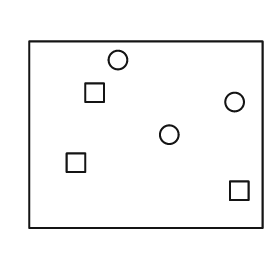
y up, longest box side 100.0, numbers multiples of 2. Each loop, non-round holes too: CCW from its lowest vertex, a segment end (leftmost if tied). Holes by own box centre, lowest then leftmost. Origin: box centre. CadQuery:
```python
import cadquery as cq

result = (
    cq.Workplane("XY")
    .moveTo(-50.0, -40.0)
    .lineTo(50.0, -40.0)
    .lineTo(50.0, 40.0)
    .lineTo(-50.0, 40.0)
    .close()
    .moveTo(36.0, -28.0)
    .lineTo(44.0, -28.0)
    .lineTo(44.0, -20.0)
    .lineTo(36.0, -20.0)
    .close()
    .moveTo(-34.0, -16.0)
    .lineTo(-26.0, -16.0)
    .lineTo(-26.0, -8.0)
    .lineTo(-34.0, -8.0)
    .close()
    .moveTo(10.0, 0.0)
    .circle(4.0)
    .moveTo(38.0, 14.0)
    .circle(4.0)
    .moveTo(-26.0, 14.0)
    .lineTo(-18.0, 14.0)
    .lineTo(-18.0, 22.0)
    .lineTo(-26.0, 22.0)
    .close()
    .moveTo(-12.0, 32.0)
    .circle(4.0)
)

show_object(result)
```